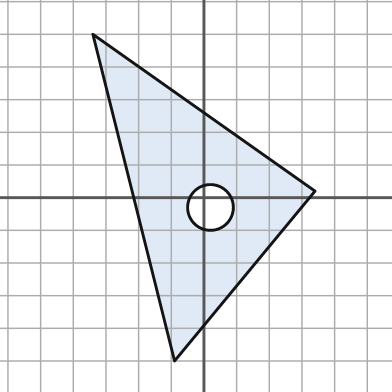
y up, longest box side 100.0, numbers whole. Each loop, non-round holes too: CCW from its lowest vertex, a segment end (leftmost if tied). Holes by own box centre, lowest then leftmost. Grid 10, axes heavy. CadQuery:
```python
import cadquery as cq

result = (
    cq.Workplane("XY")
    .moveTo(-9.0, -50.0)
    .lineTo(34.0, 2.0)
    .lineTo(-34.0, 50.0)
    .close()
    .moveTo(2.0, -3.0)
    .circle(7.0)
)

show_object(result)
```